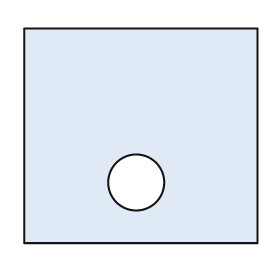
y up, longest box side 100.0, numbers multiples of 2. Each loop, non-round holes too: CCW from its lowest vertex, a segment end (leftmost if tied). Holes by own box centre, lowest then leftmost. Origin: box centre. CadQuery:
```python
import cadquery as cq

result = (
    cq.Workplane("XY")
    .moveTo(-50.0, -46.0)
    .lineTo(50.0, -46.0)
    .lineTo(50.0, 46.0)
    .lineTo(-50.0, 46.0)
    .close()
    .moveTo(-2.0, -20.0)
    .circle(12.0)
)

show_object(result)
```